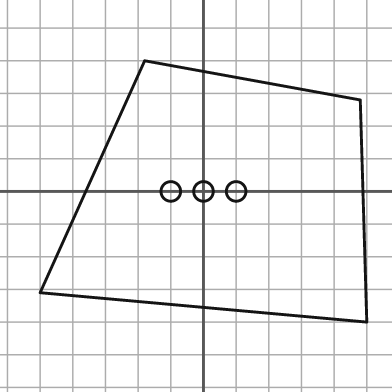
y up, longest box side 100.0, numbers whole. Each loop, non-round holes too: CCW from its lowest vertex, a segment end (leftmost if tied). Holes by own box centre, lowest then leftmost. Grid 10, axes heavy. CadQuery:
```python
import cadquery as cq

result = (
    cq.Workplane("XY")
    .moveTo(50.0, -40.0)
    .lineTo(48.0, 28.0)
    .lineTo(-18.0, 40.0)
    .lineTo(-50.0, -31.0)
    .close()
    .moveTo(-10.0, 0.0)
    .circle(3.0)
    .moveTo(0.0, 0.0)
    .circle(3.0)
    .moveTo(10.0, 0.0)
    .circle(3.0)
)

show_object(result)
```